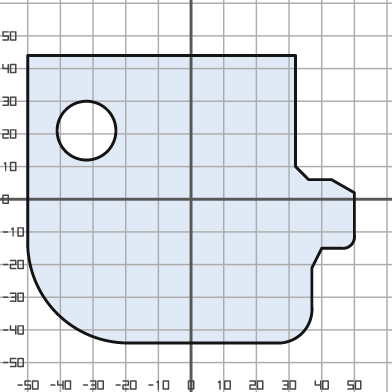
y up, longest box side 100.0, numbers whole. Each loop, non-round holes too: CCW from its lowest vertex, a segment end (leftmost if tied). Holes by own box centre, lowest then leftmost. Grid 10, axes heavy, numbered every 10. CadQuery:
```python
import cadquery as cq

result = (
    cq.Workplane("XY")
    .moveTo(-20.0, -44.0)
    .lineTo(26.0, -44.0)
    .threePointArc((34.0, -41.0), (37.0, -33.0))
    .lineTo(37.0, -21.0)
    .lineTo(40.0, -15.0)
    .lineTo(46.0, -15.0)
    .threePointArc((49.0, -14.0), (50.0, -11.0))
    .lineTo(50.0, 2.0)
    .lineTo(43.0, 6.0)
    .lineTo(36.0, 6.0)
    .lineTo(32.0, 10.0)
    .lineTo(32.0, 44.0)
    .lineTo(-50.0, 44.0)
    .lineTo(-50.0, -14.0)
    .threePointArc((-41.0, -35.0), (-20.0, -44.0))
    .close()
    .moveTo(-32.0, 21.0)
    .circle(9.0)
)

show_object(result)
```